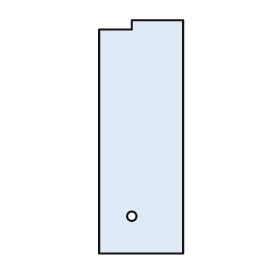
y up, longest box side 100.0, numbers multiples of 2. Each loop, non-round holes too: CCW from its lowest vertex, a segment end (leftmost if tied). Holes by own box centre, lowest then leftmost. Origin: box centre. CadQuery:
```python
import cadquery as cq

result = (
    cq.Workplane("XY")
    .moveTo(-18.0, -50.0)
    .lineTo(18.0, -50.0)
    .lineTo(18.0, 50.0)
    .lineTo(-4.0, 50.0)
    .lineTo(-4.0, 46.0)
    .lineTo(-18.0, 46.0)
    .close()
    .moveTo(-4.0, -34.0)
    .circle(2.0)
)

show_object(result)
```